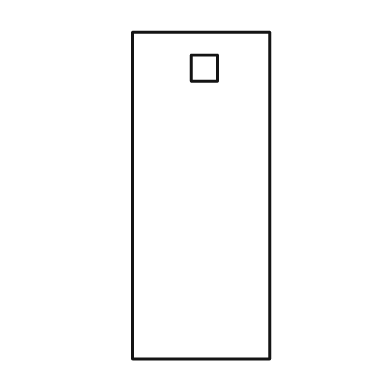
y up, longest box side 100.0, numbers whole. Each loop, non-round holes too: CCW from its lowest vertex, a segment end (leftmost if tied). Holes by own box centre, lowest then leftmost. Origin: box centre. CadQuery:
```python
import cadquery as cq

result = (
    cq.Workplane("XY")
    .moveTo(-21.0, -50.0)
    .lineTo(21.0, -50.0)
    .lineTo(21.0, 50.0)
    .lineTo(-21.0, 50.0)
    .close()
    .moveTo(-3.0, 35.0)
    .lineTo(5.0, 35.0)
    .lineTo(5.0, 43.0)
    .lineTo(-3.0, 43.0)
    .close()
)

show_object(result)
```